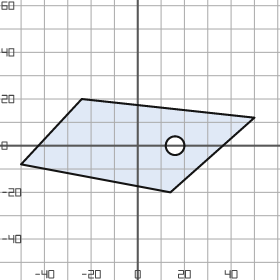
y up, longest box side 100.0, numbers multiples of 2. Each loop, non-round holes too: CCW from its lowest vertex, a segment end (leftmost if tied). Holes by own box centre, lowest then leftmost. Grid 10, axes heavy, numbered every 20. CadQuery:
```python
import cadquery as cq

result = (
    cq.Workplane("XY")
    .moveTo(14.0, -20.0)
    .lineTo(50.0, 12.0)
    .lineTo(-24.0, 20.0)
    .lineTo(-50.0, -8.0)
    .close()
    .moveTo(16.0, 0.0)
    .circle(4.0)
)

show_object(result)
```